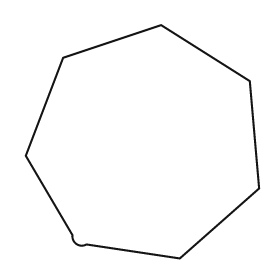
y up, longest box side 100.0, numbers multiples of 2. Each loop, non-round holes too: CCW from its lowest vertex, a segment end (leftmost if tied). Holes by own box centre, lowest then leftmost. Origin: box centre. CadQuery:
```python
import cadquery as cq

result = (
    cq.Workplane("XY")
    .moveTo(16.0, -50.0)
    .lineTo(50.0, -20.0)
    .lineTo(46.0, 26.0)
    .lineTo(8.0, 50.0)
    .lineTo(-34.0, 36.0)
    .lineTo(-50.0, -6.0)
    .lineTo(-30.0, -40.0)
    .threePointArc((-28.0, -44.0), (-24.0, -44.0))
    .close()
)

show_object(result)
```